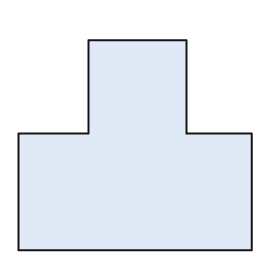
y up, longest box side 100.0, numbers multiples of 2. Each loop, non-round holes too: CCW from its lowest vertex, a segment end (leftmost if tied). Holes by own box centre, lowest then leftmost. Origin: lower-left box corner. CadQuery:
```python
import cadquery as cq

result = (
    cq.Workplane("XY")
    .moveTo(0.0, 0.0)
    .lineTo(100.0, 0.0)
    .lineTo(100.0, 50.0)
    .lineTo(72.0, 50.0)
    .lineTo(72.0, 90.0)
    .lineTo(30.0, 90.0)
    .lineTo(30.0, 50.0)
    .lineTo(0.0, 50.0)
    .close()
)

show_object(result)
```